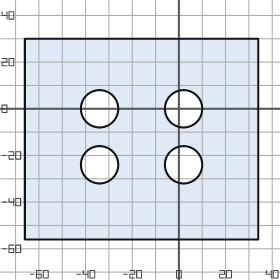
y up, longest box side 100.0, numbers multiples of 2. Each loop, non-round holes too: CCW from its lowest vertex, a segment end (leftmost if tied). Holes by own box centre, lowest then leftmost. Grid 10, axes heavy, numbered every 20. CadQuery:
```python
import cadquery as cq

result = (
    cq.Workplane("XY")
    .moveTo(-66.0, -56.0)
    .lineTo(34.0, -56.0)
    .lineTo(34.0, 30.0)
    .lineTo(-66.0, 30.0)
    .close()
    .moveTo(-34.0, -24.0)
    .circle(8.0)
    .moveTo(2.0, -24.0)
    .circle(8.0)
    .moveTo(-34.0, 0.0)
    .circle(8.0)
    .moveTo(2.0, 0.0)
    .circle(8.0)
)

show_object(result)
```